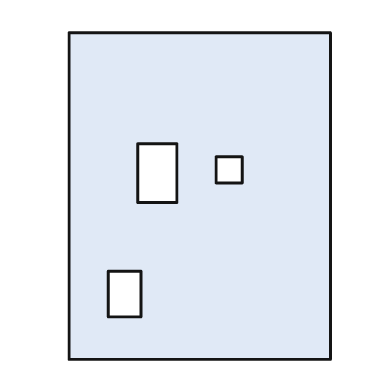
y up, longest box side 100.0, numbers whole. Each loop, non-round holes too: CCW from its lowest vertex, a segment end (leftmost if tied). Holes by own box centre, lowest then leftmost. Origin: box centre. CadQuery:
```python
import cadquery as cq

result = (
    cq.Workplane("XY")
    .moveTo(-40.0, -50.0)
    .lineTo(40.0, -50.0)
    .lineTo(40.0, 50.0)
    .lineTo(-40.0, 50.0)
    .close()
    .moveTo(-28.0, -37.0)
    .lineTo(-18.0, -37.0)
    .lineTo(-18.0, -23.0)
    .lineTo(-28.0, -23.0)
    .close()
    .moveTo(-19.0, -2.0)
    .lineTo(-7.0, -2.0)
    .lineTo(-7.0, 16.0)
    .lineTo(-19.0, 16.0)
    .close()
    .moveTo(5.0, 4.0)
    .lineTo(13.0, 4.0)
    .lineTo(13.0, 12.0)
    .lineTo(5.0, 12.0)
    .close()
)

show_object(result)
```